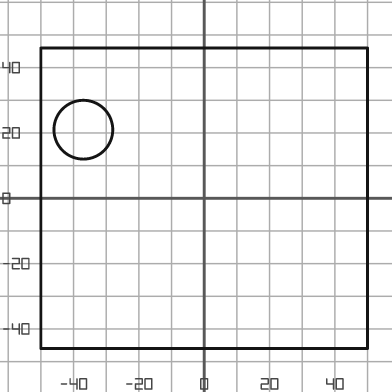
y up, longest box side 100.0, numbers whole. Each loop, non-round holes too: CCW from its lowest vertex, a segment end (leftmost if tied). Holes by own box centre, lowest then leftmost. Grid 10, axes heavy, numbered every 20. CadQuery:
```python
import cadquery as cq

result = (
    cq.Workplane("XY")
    .moveTo(-50.0, -46.0)
    .lineTo(50.0, -46.0)
    .lineTo(50.0, 46.0)
    .lineTo(-50.0, 46.0)
    .close()
    .moveTo(-37.0, 21.0)
    .circle(9.0)
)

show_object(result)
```